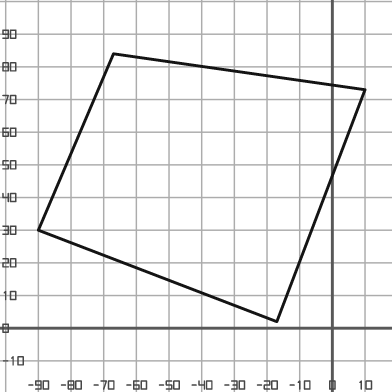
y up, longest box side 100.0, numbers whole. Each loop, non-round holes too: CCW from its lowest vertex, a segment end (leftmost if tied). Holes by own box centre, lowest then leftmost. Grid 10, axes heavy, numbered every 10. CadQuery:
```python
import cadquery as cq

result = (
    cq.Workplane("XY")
    .moveTo(-17.0, 2.0)
    .lineTo(10.0, 73.0)
    .lineTo(-67.0, 84.0)
    .lineTo(-90.0, 30.0)
    .close()
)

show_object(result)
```